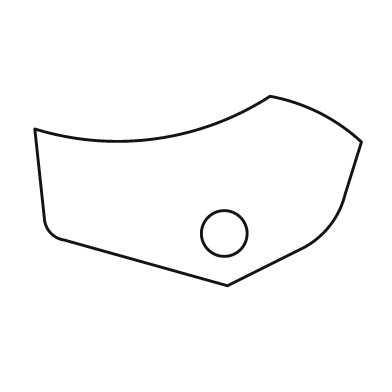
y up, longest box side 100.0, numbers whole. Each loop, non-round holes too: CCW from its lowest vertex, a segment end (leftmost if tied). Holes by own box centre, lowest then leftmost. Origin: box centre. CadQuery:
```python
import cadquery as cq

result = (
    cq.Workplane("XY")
    .moveTo(9.0, -29.0)
    .lineTo(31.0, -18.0)
    .threePointArc((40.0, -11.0), (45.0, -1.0))
    .lineTo(50.0, 15.0)
    .threePointArc((37.0, 24.0), (22.0, 29.0))
    .threePointArc((-13.0, 16.0), (-50.0, 19.0))
    .lineTo(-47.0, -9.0)
    .threePointArc((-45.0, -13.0), (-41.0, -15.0))
    .close()
    .moveTo(8.0, -13.0)
    .circle(7.0)
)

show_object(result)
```